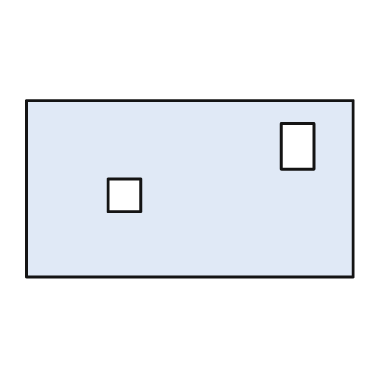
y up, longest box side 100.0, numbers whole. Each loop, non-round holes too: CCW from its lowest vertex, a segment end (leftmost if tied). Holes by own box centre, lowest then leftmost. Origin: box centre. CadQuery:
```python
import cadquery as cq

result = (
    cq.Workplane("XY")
    .moveTo(-50.0, -27.0)
    .lineTo(50.0, -27.0)
    .lineTo(50.0, 27.0)
    .lineTo(-50.0, 27.0)
    .close()
    .moveTo(-25.0, -7.0)
    .lineTo(-15.0, -7.0)
    .lineTo(-15.0, 3.0)
    .lineTo(-25.0, 3.0)
    .close()
    .moveTo(28.0, 6.0)
    .lineTo(38.0, 6.0)
    .lineTo(38.0, 20.0)
    .lineTo(28.0, 20.0)
    .close()
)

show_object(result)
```